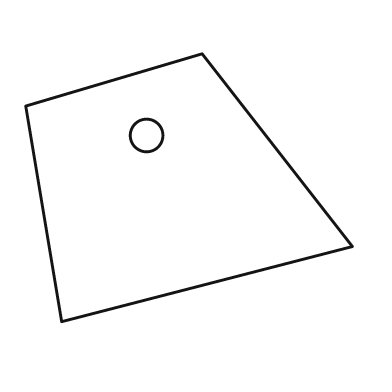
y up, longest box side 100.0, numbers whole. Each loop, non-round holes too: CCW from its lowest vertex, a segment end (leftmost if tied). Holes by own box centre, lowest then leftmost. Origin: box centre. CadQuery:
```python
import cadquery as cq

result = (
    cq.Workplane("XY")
    .moveTo(-39.0, -41.0)
    .lineTo(50.0, -18.0)
    .lineTo(4.0, 41.0)
    .lineTo(-50.0, 25.0)
    .close()
    .moveTo(-13.0, 16.0)
    .circle(5.0)
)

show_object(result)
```